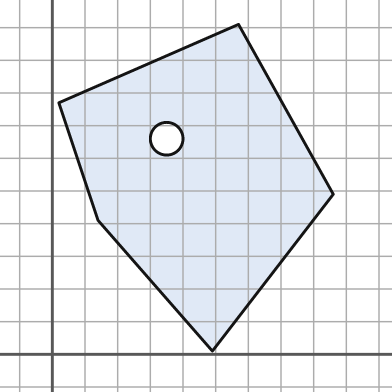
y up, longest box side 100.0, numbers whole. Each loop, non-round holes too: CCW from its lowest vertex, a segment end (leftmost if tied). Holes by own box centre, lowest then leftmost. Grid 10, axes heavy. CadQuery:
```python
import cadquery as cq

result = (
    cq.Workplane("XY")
    .moveTo(49.0, 1.0)
    .lineTo(86.0, 49.0)
    .lineTo(57.0, 101.0)
    .lineTo(2.0, 77.0)
    .lineTo(14.0, 41.0)
    .close()
    .moveTo(35.0, 66.0)
    .circle(5.0)
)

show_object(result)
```